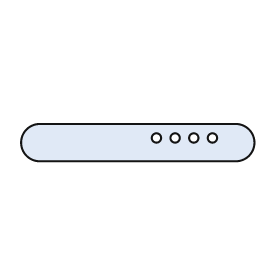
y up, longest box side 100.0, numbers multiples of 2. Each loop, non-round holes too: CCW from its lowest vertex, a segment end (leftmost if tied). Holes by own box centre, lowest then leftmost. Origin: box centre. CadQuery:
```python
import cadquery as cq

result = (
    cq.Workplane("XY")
    .moveTo(-42.0, -8.0)
    .lineTo(42.0, -8.0)
    .threePointArc((50.0, 0.0), (42.0, 8.0))
    .lineTo(-42.0, 8.0)
    .threePointArc((-50.0, 0.0), (-42.0, -8.0))
    .close()
    .moveTo(8.0, 2.0)
    .circle(2.0)
    .moveTo(16.0, 2.0)
    .circle(2.0)
    .moveTo(24.0, 2.0)
    .circle(2.0)
    .moveTo(32.0, 2.0)
    .circle(2.0)
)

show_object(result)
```